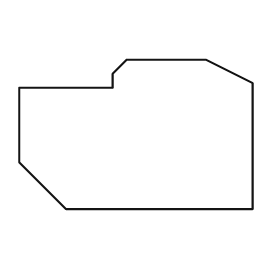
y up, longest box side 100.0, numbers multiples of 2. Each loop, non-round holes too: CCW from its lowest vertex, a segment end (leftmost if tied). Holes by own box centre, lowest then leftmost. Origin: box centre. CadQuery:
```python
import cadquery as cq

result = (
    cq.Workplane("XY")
    .moveTo(-30.0, -32.0)
    .lineTo(50.0, -32.0)
    .lineTo(50.0, 22.0)
    .lineTo(30.0, 32.0)
    .lineTo(-4.0, 32.0)
    .lineTo(-10.0, 26.0)
    .lineTo(-10.0, 20.0)
    .lineTo(-50.0, 20.0)
    .lineTo(-50.0, -12.0)
    .close()
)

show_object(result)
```